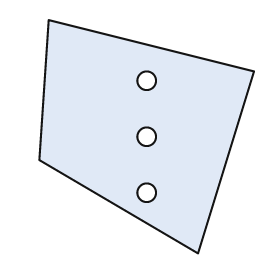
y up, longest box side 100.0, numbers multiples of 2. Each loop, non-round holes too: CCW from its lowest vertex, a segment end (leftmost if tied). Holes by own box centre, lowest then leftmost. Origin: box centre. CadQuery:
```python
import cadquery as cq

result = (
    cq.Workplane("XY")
    .moveTo(22.0, -50.0)
    .lineTo(46.0, 28.0)
    .lineTo(-42.0, 50.0)
    .lineTo(-46.0, -10.0)
    .close()
    .moveTo(0.0, -24.0)
    .circle(4.0)
    .moveTo(0.0, 0.0)
    .circle(4.0)
    .moveTo(0.0, 24.0)
    .circle(4.0)
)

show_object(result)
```